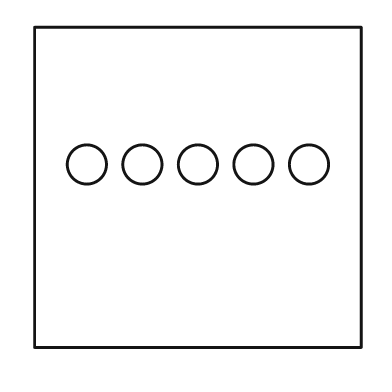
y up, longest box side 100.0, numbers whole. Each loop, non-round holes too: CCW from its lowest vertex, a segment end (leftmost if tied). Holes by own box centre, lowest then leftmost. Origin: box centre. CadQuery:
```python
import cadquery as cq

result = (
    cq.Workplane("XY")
    .moveTo(-50.0, -49.0)
    .lineTo(50.0, -49.0)
    .lineTo(50.0, 49.0)
    .lineTo(-50.0, 49.0)
    .close()
    .moveTo(-34.0, 7.0)
    .circle(6.0)
    .moveTo(-17.0, 7.0)
    .circle(6.0)
    .moveTo(0.0, 7.0)
    .circle(6.0)
    .moveTo(17.0, 7.0)
    .circle(6.0)
    .moveTo(34.0, 7.0)
    .circle(6.0)
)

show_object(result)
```